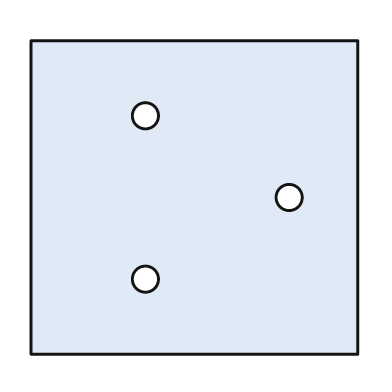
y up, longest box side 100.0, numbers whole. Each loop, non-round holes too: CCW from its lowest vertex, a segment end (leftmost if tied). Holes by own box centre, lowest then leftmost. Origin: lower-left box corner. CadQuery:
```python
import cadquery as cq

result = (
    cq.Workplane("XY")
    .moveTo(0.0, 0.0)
    .lineTo(100.0, 0.0)
    .lineTo(100.0, 96.0)
    .lineTo(0.0, 96.0)
    .close()
    .moveTo(35.0, 23.0)
    .circle(4.0)
    .moveTo(79.0, 48.0)
    .circle(4.0)
    .moveTo(35.0, 73.0)
    .circle(4.0)
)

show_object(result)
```